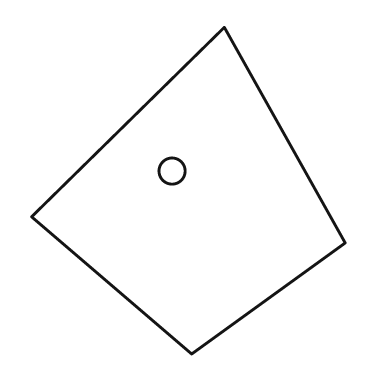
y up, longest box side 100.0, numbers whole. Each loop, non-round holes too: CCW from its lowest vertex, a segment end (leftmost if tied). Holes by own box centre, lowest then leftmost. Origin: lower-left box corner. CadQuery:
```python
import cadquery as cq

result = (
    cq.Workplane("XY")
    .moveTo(49.0, 0.0)
    .lineTo(96.0, 34.0)
    .lineTo(59.0, 100.0)
    .lineTo(0.0, 42.0)
    .close()
    .moveTo(43.0, 56.0)
    .circle(4.0)
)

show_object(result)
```